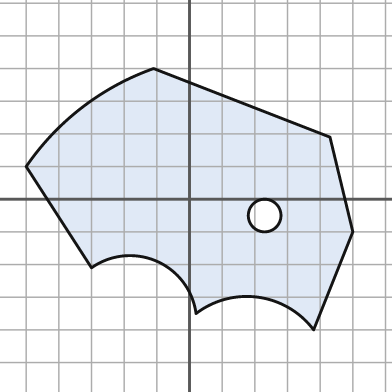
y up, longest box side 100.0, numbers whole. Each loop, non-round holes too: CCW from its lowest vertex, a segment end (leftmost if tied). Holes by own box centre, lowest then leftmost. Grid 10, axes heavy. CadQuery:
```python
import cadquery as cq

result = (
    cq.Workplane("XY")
    .moveTo(38.0, -40.0)
    .lineTo(50.0, -10.0)
    .lineTo(43.0, 19.0)
    .lineTo(-11.0, 40.0)
    .threePointArc((-33.0, 28.0), (-50.0, 10.0))
    .lineTo(-30.0, -21.0)
    .threePointArc((-10.0, -19.0), (2.0, -35.0))
    .threePointArc((21.0, -30.0), (38.0, -40.0))
    .close()
    .moveTo(23.0, -5.0)
    .circle(5.0)
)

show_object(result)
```